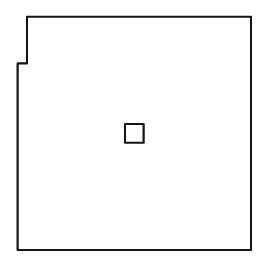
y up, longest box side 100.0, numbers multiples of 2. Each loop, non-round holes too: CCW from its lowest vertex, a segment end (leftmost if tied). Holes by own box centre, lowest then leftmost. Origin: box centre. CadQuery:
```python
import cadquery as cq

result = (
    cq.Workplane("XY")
    .moveTo(-50.0, -50.0)
    .lineTo(50.0, -50.0)
    .lineTo(50.0, 50.0)
    .lineTo(-46.0, 50.0)
    .lineTo(-46.0, 30.0)
    .lineTo(-50.0, 30.0)
    .close()
    .moveTo(-4.0, -4.0)
    .lineTo(4.0, -4.0)
    .lineTo(4.0, 4.0)
    .lineTo(-4.0, 4.0)
    .close()
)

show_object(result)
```